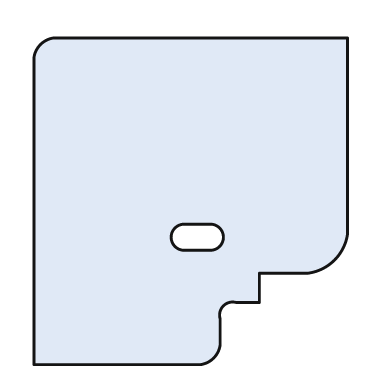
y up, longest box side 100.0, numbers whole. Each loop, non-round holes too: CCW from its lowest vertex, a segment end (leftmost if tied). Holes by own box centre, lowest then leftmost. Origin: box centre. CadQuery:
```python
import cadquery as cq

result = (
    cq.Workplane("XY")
    .moveTo(-48.0, -50.0)
    .lineTo(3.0, -50.0)
    .threePointArc((7.0, -48.0), (9.0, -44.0))
    .lineTo(9.0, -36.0)
    .threePointArc((10.0, -32.0), (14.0, -31.0))
    .lineTo(21.0, -31.0)
    .lineTo(21.0, -22.0)
    .lineTo(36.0, -22.0)
    .threePointArc((44.0, -18.0), (48.0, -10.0))
    .lineTo(48.0, 50.0)
    .lineTo(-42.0, 50.0)
    .threePointArc((-46.0, 48.0), (-48.0, 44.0))
    .close()
    .moveTo(-2.0, -15.0)
    .lineTo(6.0, -15.0)
    .threePointArc((10.0, -11.0), (6.0, -7.0))
    .lineTo(-2.0, -7.0)
    .threePointArc((-6.0, -11.0), (-2.0, -15.0))
    .close()
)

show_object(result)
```